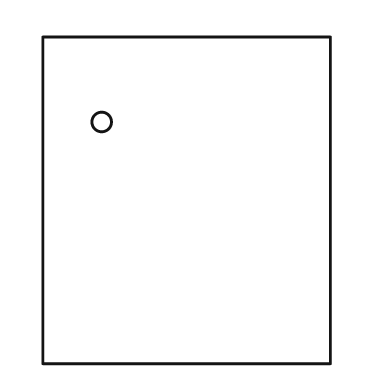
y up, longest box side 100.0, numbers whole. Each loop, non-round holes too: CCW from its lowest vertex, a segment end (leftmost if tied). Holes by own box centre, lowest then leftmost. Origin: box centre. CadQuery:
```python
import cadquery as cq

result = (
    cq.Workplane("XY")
    .moveTo(-44.0, -50.0)
    .lineTo(44.0, -50.0)
    .lineTo(44.0, 50.0)
    .lineTo(-44.0, 50.0)
    .close()
    .moveTo(-26.0, 24.0)
    .circle(3.0)
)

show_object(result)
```